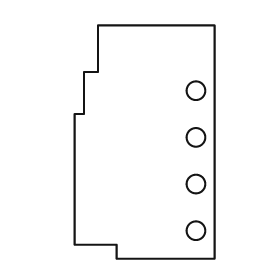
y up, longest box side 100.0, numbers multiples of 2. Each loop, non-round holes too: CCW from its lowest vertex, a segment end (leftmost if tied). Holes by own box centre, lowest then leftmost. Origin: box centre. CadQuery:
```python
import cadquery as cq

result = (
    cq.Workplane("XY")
    .moveTo(-12.0, -50.0)
    .lineTo(30.0, -50.0)
    .lineTo(30.0, 50.0)
    .lineTo(-20.0, 50.0)
    .lineTo(-20.0, 30.0)
    .lineTo(-26.0, 30.0)
    .lineTo(-26.0, 12.0)
    .lineTo(-30.0, 12.0)
    .lineTo(-30.0, -44.0)
    .lineTo(-12.0, -44.0)
    .close()
    .moveTo(22.0, -38.0)
    .circle(4.0)
    .moveTo(22.0, -18.0)
    .circle(4.0)
    .moveTo(22.0, 2.0)
    .circle(4.0)
    .moveTo(22.0, 22.0)
    .circle(4.0)
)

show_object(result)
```